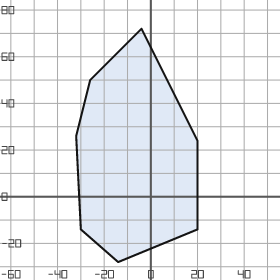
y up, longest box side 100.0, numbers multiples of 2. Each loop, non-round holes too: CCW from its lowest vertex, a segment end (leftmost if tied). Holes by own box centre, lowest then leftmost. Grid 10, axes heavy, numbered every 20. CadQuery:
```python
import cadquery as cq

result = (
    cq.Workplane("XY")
    .moveTo(-14.0, -28.0)
    .lineTo(20.0, -14.0)
    .lineTo(20.0, 24.0)
    .lineTo(-4.0, 72.0)
    .lineTo(-26.0, 50.0)
    .lineTo(-32.0, 26.0)
    .lineTo(-30.0, -14.0)
    .close()
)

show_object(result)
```